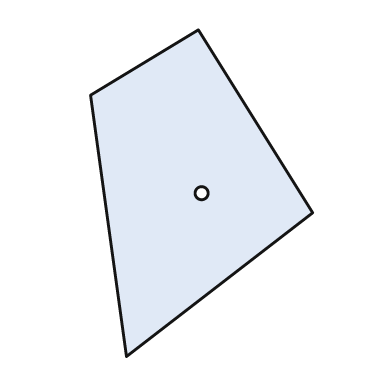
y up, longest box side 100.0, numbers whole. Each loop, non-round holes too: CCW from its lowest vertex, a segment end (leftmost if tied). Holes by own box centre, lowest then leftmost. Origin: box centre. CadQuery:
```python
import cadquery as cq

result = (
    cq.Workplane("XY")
    .moveTo(-23.0, -50.0)
    .lineTo(34.0, -6.0)
    .lineTo(-1.0, 50.0)
    .lineTo(-34.0, 30.0)
    .close()
    .moveTo(0.0, 0.0)
    .circle(2.0)
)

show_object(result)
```